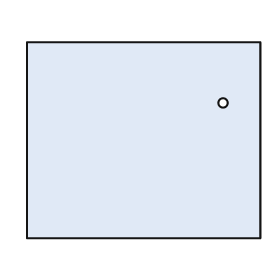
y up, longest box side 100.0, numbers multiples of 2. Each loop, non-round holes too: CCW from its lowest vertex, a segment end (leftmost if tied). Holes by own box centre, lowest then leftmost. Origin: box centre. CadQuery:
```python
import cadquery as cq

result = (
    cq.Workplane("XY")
    .moveTo(-50.0, -42.0)
    .lineTo(50.0, -42.0)
    .lineTo(50.0, 42.0)
    .lineTo(-50.0, 42.0)
    .close()
    .moveTo(34.0, 16.0)
    .circle(2.0)
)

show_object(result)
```